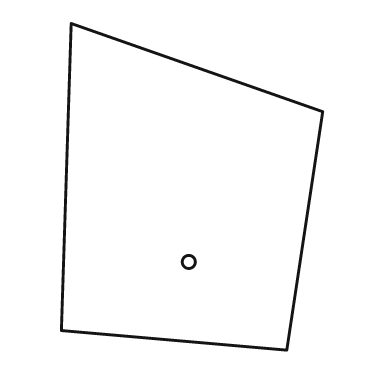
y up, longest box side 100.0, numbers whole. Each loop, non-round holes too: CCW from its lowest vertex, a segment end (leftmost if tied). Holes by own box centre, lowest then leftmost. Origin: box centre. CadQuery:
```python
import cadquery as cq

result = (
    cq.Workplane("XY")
    .moveTo(29.0, -50.0)
    .lineTo(40.0, 23.0)
    .lineTo(-37.0, 50.0)
    .lineTo(-40.0, -44.0)
    .close()
    .moveTo(-1.0, -23.0)
    .circle(2.0)
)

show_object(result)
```